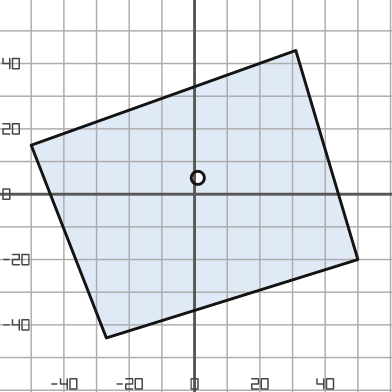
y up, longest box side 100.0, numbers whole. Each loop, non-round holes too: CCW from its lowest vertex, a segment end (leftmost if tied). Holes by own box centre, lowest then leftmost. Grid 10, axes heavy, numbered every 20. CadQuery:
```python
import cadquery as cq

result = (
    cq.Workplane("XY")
    .moveTo(-27.0, -44.0)
    .lineTo(50.0, -20.0)
    .lineTo(31.0, 44.0)
    .lineTo(-50.0, 15.0)
    .close()
    .moveTo(1.0, 5.0)
    .circle(2.0)
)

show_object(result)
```